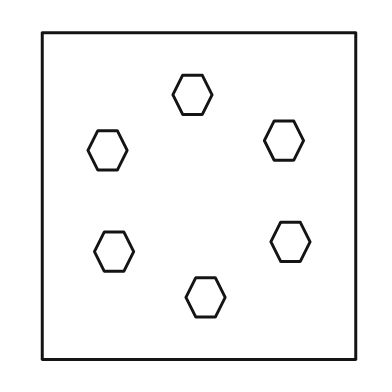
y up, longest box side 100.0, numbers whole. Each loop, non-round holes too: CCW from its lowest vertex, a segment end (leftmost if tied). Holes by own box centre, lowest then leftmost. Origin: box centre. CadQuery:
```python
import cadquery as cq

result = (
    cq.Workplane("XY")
    .moveTo(-48.0, -50.0)
    .lineTo(48.0, -50.0)
    .lineTo(48.0, 50.0)
    .lineTo(-48.0, 50.0)
    .close()
    .moveTo(-1.0, -37.0)
    .lineTo(5.0, -37.0)
    .lineTo(8.0, -31.0)
    .lineTo(5.0, -25.0)
    .lineTo(-1.0, -25.0)
    .lineTo(-4.0, -31.0)
    .close()
    .moveTo(-29.0, -23.0)
    .lineTo(-23.0, -23.0)
    .lineTo(-20.0, -17.0)
    .lineTo(-23.0, -11.0)
    .lineTo(-29.0, -11.0)
    .lineTo(-32.0, -17.0)
    .close()
    .moveTo(25.0, -20.0)
    .lineTo(31.0, -20.0)
    .lineTo(34.0, -14.0)
    .lineTo(31.0, -8.0)
    .lineTo(25.0, -8.0)
    .lineTo(22.0, -14.0)
    .close()
    .moveTo(-31.0, 8.0)
    .lineTo(-25.0, 8.0)
    .lineTo(-22.0, 14.0)
    .lineTo(-25.0, 20.0)
    .lineTo(-31.0, 20.0)
    .lineTo(-34.0, 14.0)
    .close()
    .moveTo(23.0, 11.0)
    .lineTo(29.0, 11.0)
    .lineTo(32.0, 17.0)
    .lineTo(29.0, 23.0)
    .lineTo(23.0, 23.0)
    .lineTo(20.0, 17.0)
    .close()
    .moveTo(-5.0, 25.0)
    .lineTo(1.0, 25.0)
    .lineTo(4.0, 31.0)
    .lineTo(1.0, 37.0)
    .lineTo(-5.0, 37.0)
    .lineTo(-8.0, 31.0)
    .close()
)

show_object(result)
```